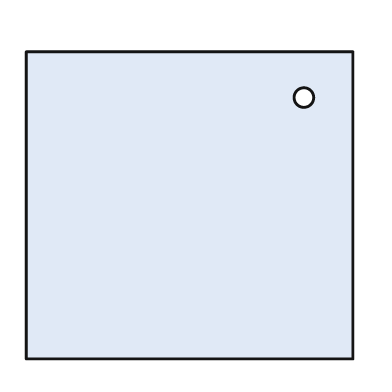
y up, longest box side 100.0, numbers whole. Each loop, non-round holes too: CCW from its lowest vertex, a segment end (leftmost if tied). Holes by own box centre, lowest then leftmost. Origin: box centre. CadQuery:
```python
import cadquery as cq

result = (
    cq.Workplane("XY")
    .moveTo(-50.0, -47.0)
    .lineTo(50.0, -47.0)
    .lineTo(50.0, 47.0)
    .lineTo(-50.0, 47.0)
    .close()
    .moveTo(35.0, 33.0)
    .circle(3.0)
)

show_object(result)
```